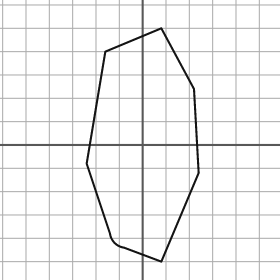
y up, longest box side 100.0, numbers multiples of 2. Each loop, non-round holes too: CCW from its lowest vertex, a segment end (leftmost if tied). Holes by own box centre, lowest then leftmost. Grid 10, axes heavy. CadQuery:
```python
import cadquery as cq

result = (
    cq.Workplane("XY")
    .moveTo(8.0, -50.0)
    .lineTo(24.0, -12.0)
    .lineTo(22.0, 24.0)
    .lineTo(8.0, 50.0)
    .lineTo(-16.0, 40.0)
    .lineTo(-24.0, -8.0)
    .lineTo(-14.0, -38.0)
    .threePointArc((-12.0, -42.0), (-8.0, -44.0))
    .close()
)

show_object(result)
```